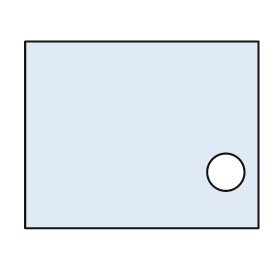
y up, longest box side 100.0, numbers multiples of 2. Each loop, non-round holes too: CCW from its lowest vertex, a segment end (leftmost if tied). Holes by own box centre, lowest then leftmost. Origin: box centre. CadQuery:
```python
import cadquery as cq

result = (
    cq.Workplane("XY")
    .moveTo(-50.0, -40.0)
    .lineTo(50.0, -40.0)
    .lineTo(50.0, 40.0)
    .lineTo(-50.0, 40.0)
    .close()
    .moveTo(36.0, -16.0)
    .circle(8.0)
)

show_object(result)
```